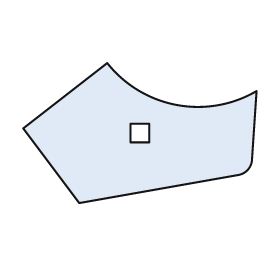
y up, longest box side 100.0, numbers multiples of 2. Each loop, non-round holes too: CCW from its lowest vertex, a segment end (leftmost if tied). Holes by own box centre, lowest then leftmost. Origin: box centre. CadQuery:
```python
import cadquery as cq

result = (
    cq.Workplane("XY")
    .moveTo(-26.0, -30.0)
    .lineTo(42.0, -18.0)
    .threePointArc((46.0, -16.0), (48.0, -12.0))
    .lineTo(50.0, 18.0)
    .threePointArc((16.0, 12.0), (-14.0, 30.0))
    .lineTo(-50.0, 2.0)
    .close()
    .moveTo(-4.0, -4.0)
    .lineTo(4.0, -4.0)
    .lineTo(4.0, 4.0)
    .lineTo(-4.0, 4.0)
    .close()
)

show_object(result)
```